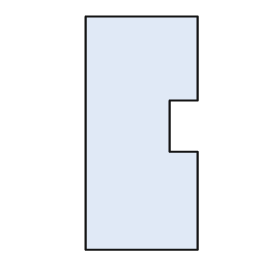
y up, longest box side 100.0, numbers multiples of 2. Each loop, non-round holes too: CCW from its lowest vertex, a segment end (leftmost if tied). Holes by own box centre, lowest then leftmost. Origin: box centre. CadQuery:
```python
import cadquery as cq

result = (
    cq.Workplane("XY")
    .moveTo(-24.0, -50.0)
    .lineTo(24.0, -50.0)
    .lineTo(24.0, -8.0)
    .lineTo(12.0, -8.0)
    .lineTo(12.0, 14.0)
    .lineTo(24.0, 14.0)
    .lineTo(24.0, 50.0)
    .lineTo(-24.0, 50.0)
    .close()
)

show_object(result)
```